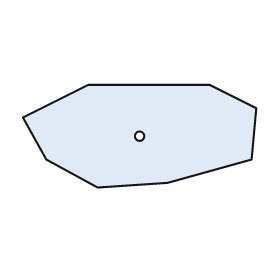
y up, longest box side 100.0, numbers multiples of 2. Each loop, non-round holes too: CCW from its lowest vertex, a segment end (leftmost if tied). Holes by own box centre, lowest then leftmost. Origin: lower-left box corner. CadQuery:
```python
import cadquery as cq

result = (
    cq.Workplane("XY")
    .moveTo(32.0, 0.0)
    .lineTo(62.0, 2.0)
    .lineTo(98.0, 12.0)
    .lineTo(100.0, 34.0)
    .lineTo(80.0, 44.0)
    .lineTo(28.0, 44.0)
    .lineTo(0.0, 30.0)
    .lineTo(10.0, 12.0)
    .close()
    .moveTo(50.0, 22.0)
    .circle(2.0)
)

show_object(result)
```